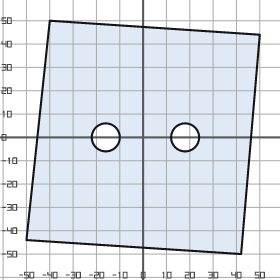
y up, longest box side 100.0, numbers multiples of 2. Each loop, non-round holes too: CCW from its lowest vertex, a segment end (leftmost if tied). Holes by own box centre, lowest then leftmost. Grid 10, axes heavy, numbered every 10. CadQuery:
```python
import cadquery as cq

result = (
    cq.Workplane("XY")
    .moveTo(42.0, -50.0)
    .lineTo(50.0, 44.0)
    .lineTo(-40.0, 50.0)
    .lineTo(-50.0, -44.0)
    .close()
    .moveTo(-16.0, 0.0)
    .circle(6.0)
    .moveTo(18.0, 0.0)
    .circle(6.0)
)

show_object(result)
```